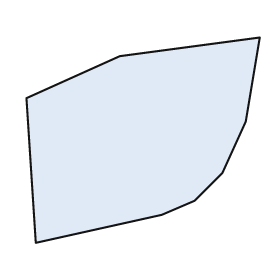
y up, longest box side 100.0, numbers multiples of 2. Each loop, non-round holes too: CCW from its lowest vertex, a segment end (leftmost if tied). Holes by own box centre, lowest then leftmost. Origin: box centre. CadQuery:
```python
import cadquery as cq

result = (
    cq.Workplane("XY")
    .moveTo(-46.0, -44.0)
    .lineTo(8.0, -32.0)
    .lineTo(22.0, -26.0)
    .lineTo(34.0, -14.0)
    .lineTo(44.0, 8.0)
    .lineTo(50.0, 44.0)
    .lineTo(-10.0, 36.0)
    .lineTo(-50.0, 18.0)
    .close()
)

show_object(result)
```